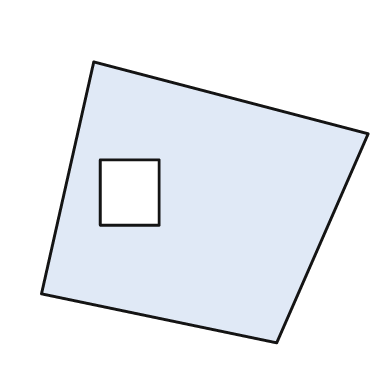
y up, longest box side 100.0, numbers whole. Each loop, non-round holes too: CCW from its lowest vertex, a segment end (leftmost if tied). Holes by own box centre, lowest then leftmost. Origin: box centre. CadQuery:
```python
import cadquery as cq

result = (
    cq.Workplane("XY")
    .moveTo(22.0, -43.0)
    .lineTo(50.0, 21.0)
    .lineTo(-34.0, 43.0)
    .lineTo(-50.0, -28.0)
    .close()
    .moveTo(-32.0, -7.0)
    .lineTo(-14.0, -7.0)
    .lineTo(-14.0, 13.0)
    .lineTo(-32.0, 13.0)
    .close()
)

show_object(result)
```